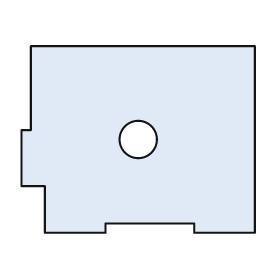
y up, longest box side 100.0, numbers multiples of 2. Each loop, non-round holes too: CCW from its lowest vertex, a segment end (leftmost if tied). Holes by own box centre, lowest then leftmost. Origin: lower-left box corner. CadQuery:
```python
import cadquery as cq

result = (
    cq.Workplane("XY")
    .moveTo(10.0, 0.0)
    .lineTo(36.0, 0.0)
    .lineTo(36.0, 4.0)
    .lineTo(74.0, 4.0)
    .lineTo(74.0, 0.0)
    .lineTo(100.0, 0.0)
    .lineTo(100.0, 80.0)
    .lineTo(4.0, 80.0)
    .lineTo(4.0, 44.0)
    .lineTo(0.0, 44.0)
    .lineTo(0.0, 20.0)
    .lineTo(10.0, 20.0)
    .close()
    .moveTo(50.0, 40.0)
    .circle(8.0)
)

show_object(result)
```